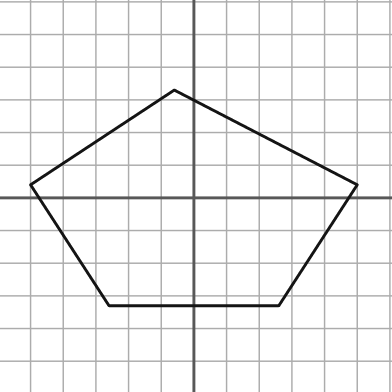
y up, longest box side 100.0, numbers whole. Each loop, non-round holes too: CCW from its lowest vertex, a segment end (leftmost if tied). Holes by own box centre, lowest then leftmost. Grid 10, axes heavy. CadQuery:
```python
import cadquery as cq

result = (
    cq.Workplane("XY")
    .moveTo(-26.0, -33.0)
    .lineTo(26.0, -33.0)
    .lineTo(50.0, 4.0)
    .lineTo(-6.0, 33.0)
    .lineTo(-50.0, 4.0)
    .close()
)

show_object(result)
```